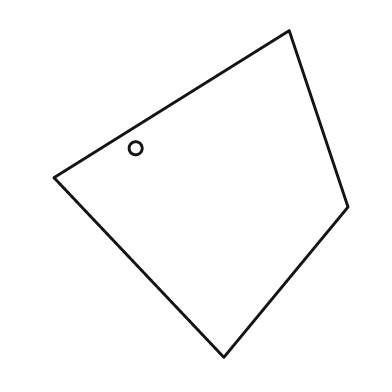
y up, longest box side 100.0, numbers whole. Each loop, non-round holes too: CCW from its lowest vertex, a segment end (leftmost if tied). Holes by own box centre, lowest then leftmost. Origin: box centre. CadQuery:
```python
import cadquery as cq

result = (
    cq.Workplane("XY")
    .moveTo(7.0, -50.0)
    .lineTo(45.0, -4.0)
    .lineTo(27.0, 50.0)
    .lineTo(-45.0, 5.0)
    .close()
    .moveTo(-20.0, 14.0)
    .circle(2.0)
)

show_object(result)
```